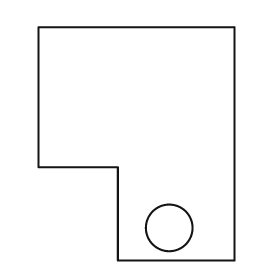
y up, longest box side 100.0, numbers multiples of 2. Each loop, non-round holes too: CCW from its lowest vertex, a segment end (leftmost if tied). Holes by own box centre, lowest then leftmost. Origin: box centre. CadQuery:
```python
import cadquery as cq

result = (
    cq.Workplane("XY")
    .moveTo(-8.0, -50.0)
    .lineTo(42.0, -50.0)
    .lineTo(42.0, 50.0)
    .lineTo(-42.0, 50.0)
    .lineTo(-42.0, -10.0)
    .lineTo(-8.0, -10.0)
    .close()
    .moveTo(14.0, -36.0)
    .circle(10.0)
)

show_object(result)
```